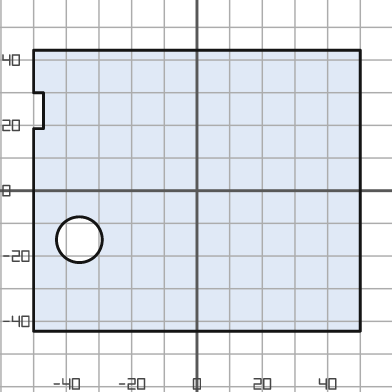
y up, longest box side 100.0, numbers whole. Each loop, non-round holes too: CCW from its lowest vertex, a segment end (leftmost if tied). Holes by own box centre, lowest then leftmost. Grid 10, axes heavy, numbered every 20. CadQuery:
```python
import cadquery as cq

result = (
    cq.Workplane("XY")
    .moveTo(-50.0, -43.0)
    .lineTo(50.0, -43.0)
    .lineTo(50.0, 43.0)
    .lineTo(-50.0, 43.0)
    .lineTo(-50.0, 30.0)
    .lineTo(-47.0, 30.0)
    .lineTo(-47.0, 19.0)
    .lineTo(-50.0, 19.0)
    .close()
    .moveTo(-36.0, -15.0)
    .circle(7.0)
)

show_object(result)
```